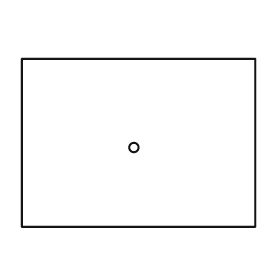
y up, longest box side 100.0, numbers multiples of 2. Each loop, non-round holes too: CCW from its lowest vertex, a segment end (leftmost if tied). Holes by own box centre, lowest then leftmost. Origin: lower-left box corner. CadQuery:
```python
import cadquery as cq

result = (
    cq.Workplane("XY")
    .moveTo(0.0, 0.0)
    .lineTo(100.0, 0.0)
    .lineTo(100.0, 72.0)
    .lineTo(0.0, 72.0)
    .close()
    .moveTo(48.0, 34.0)
    .circle(2.0)
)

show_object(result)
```